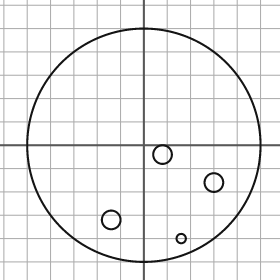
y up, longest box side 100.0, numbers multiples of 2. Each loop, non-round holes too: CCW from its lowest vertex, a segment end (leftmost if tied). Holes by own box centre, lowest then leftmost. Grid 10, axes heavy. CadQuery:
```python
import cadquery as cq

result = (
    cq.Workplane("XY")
    .moveTo(0.0, 0.0)
    .circle(50.0)
    .moveTo(16.0, -40.0)
    .circle(2.0)
    .moveTo(-14.0, -32.0)
    .circle(4.0)
    .moveTo(30.0, -16.0)
    .circle(4.0)
    .moveTo(8.0, -4.0)
    .circle(4.0)
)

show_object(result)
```